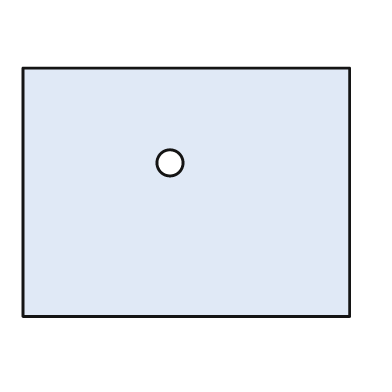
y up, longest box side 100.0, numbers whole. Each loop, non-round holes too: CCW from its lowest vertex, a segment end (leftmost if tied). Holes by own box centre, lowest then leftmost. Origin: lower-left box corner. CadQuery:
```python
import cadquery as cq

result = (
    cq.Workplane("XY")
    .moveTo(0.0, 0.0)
    .lineTo(100.0, 0.0)
    .lineTo(100.0, 76.0)
    .lineTo(0.0, 76.0)
    .close()
    .moveTo(45.0, 47.0)
    .circle(4.0)
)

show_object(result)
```